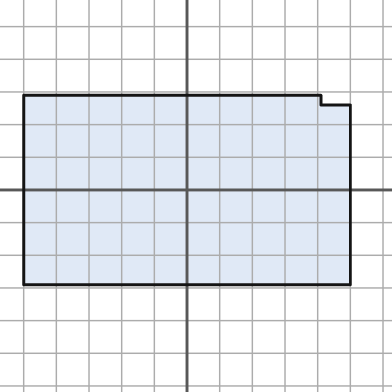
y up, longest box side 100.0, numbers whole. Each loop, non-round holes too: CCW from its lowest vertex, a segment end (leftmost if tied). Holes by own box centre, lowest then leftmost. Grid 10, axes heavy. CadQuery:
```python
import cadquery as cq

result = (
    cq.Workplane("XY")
    .moveTo(-50.0, -29.0)
    .lineTo(50.0, -29.0)
    .lineTo(50.0, 26.0)
    .lineTo(41.0, 26.0)
    .lineTo(41.0, 29.0)
    .lineTo(-50.0, 29.0)
    .close()
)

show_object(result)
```